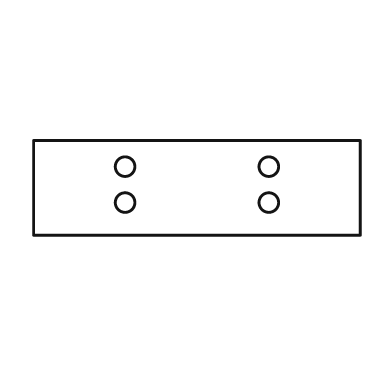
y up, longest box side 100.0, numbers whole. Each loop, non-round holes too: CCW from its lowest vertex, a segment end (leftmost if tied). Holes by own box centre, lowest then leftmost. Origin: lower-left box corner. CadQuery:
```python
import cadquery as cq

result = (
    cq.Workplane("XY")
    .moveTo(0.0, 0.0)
    .lineTo(100.0, 0.0)
    .lineTo(100.0, 29.0)
    .lineTo(0.0, 29.0)
    .close()
    .moveTo(28.0, 10.0)
    .circle(3.0)
    .moveTo(72.0, 10.0)
    .circle(3.0)
    .moveTo(28.0, 21.0)
    .circle(3.0)
    .moveTo(72.0, 21.0)
    .circle(3.0)
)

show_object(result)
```